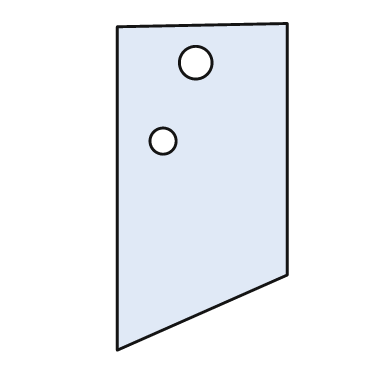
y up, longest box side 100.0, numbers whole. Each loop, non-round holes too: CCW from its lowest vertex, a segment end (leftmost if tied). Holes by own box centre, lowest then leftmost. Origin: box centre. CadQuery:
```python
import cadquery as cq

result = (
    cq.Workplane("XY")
    .moveTo(-26.0, -50.0)
    .lineTo(26.0, -27.0)
    .lineTo(26.0, 50.0)
    .lineTo(-26.0, 49.0)
    .close()
    .moveTo(-12.0, 14.0)
    .circle(4.0)
    .moveTo(-2.0, 38.0)
    .circle(5.0)
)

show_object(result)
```